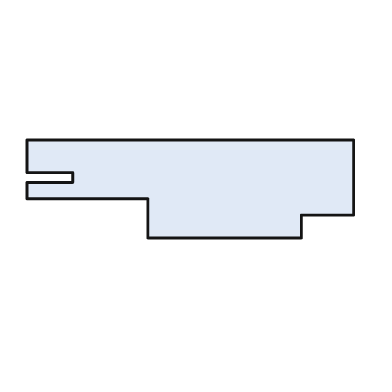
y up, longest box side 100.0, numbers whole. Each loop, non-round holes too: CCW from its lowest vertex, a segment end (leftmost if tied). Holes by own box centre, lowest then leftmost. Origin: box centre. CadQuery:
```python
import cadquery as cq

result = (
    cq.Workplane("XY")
    .moveTo(-13.0, -15.0)
    .lineTo(34.0, -15.0)
    .lineTo(34.0, -8.0)
    .lineTo(50.0, -8.0)
    .lineTo(50.0, 15.0)
    .lineTo(-50.0, 15.0)
    .lineTo(-50.0, 5.0)
    .lineTo(-36.0, 5.0)
    .lineTo(-36.0, 2.0)
    .lineTo(-50.0, 2.0)
    .lineTo(-50.0, -3.0)
    .lineTo(-13.0, -3.0)
    .close()
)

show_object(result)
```